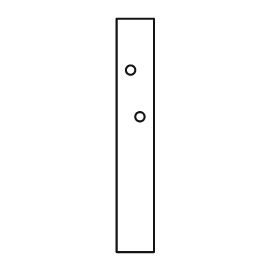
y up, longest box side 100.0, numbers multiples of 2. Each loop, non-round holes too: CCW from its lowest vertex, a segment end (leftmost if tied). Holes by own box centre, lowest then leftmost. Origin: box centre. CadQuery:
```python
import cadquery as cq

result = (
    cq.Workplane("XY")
    .moveTo(-8.0, -50.0)
    .lineTo(8.0, -50.0)
    .lineTo(8.0, 50.0)
    .lineTo(-8.0, 50.0)
    .close()
    .moveTo(2.0, 8.0)
    .circle(2.0)
    .moveTo(-2.0, 28.0)
    .circle(2.0)
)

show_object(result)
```